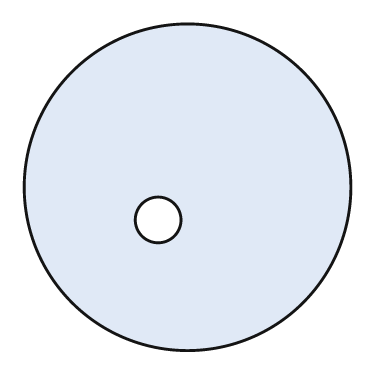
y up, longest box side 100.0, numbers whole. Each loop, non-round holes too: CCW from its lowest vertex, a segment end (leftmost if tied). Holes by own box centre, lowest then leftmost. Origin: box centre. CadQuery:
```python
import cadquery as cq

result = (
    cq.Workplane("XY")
    .moveTo(0.0, 0.0)
    .circle(50.0)
    .moveTo(-9.0, -10.0)
    .circle(7.0)
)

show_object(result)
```